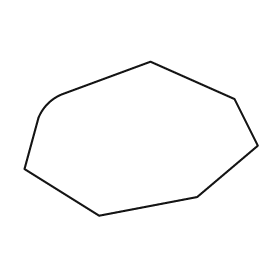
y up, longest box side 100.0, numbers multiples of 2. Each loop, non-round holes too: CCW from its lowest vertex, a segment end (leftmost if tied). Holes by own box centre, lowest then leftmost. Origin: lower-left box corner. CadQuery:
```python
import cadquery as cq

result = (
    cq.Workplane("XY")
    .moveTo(32.0, 0.0)
    .lineTo(74.0, 8.0)
    .lineTo(100.0, 30.0)
    .lineTo(90.0, 50.0)
    .lineTo(54.0, 66.0)
    .lineTo(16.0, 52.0)
    .threePointArc((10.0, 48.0), (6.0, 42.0))
    .lineTo(0.0, 20.0)
    .close()
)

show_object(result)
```